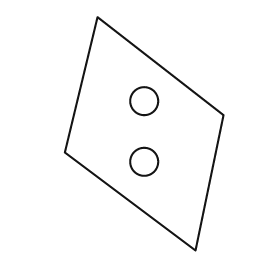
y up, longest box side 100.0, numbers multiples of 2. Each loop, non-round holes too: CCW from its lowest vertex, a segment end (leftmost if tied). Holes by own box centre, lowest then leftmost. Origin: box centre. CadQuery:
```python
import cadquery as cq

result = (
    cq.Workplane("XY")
    .moveTo(22.0, -50.0)
    .lineTo(34.0, 8.0)
    .lineTo(-20.0, 50.0)
    .lineTo(-34.0, -8.0)
    .close()
    .moveTo(0.0, -12.0)
    .circle(6.0)
    .moveTo(0.0, 14.0)
    .circle(6.0)
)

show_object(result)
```